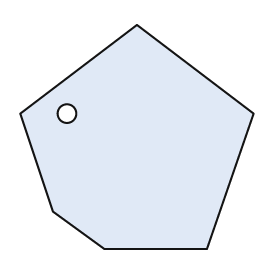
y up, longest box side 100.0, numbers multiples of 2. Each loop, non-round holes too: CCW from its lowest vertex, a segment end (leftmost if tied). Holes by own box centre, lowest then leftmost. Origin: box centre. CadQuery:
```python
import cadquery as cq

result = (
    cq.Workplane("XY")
    .moveTo(-14.0, -48.0)
    .lineTo(30.0, -48.0)
    .lineTo(50.0, 10.0)
    .lineTo(0.0, 48.0)
    .lineTo(-50.0, 10.0)
    .lineTo(-36.0, -32.0)
    .close()
    .moveTo(-30.0, 10.0)
    .circle(4.0)
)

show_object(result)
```